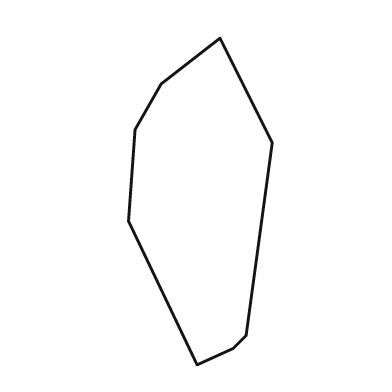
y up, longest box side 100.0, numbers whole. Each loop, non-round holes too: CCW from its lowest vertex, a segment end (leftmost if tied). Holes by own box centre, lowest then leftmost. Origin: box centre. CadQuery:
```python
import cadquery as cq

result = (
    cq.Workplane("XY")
    .moveTo(-1.0, -50.0)
    .lineTo(10.0, -45.0)
    .lineTo(14.0, -41.0)
    .lineTo(22.0, 18.0)
    .lineTo(6.0, 50.0)
    .lineTo(-12.0, 36.0)
    .lineTo(-20.0, 22.0)
    .lineTo(-22.0, -6.0)
    .close()
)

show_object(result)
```